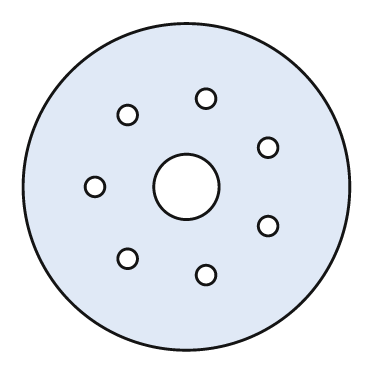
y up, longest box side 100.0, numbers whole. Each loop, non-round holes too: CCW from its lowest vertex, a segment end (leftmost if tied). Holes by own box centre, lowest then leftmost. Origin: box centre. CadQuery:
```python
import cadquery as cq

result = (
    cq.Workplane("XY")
    .moveTo(0.0, 0.0)
    .circle(50.0)
    .moveTo(6.0, -27.0)
    .circle(3.0)
    .moveTo(-18.0, -22.0)
    .circle(3.0)
    .moveTo(25.0, -12.0)
    .circle(3.0)
    .moveTo(-28.0, 0.0)
    .circle(3.0)
    .moveTo(0.0, 0.0)
    .circle(10.0)
    .moveTo(25.0, 12.0)
    .circle(3.0)
    .moveTo(-18.0, 22.0)
    .circle(3.0)
    .moveTo(6.0, 27.0)
    .circle(3.0)
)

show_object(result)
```